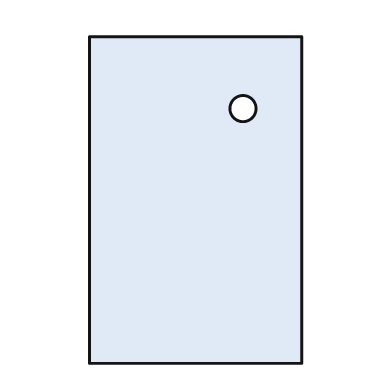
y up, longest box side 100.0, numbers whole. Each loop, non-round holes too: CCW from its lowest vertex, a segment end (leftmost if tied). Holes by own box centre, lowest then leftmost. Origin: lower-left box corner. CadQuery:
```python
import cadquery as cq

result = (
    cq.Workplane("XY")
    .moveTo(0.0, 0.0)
    .lineTo(65.0, 0.0)
    .lineTo(65.0, 100.0)
    .lineTo(0.0, 100.0)
    .close()
    .moveTo(47.0, 78.0)
    .circle(4.0)
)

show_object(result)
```